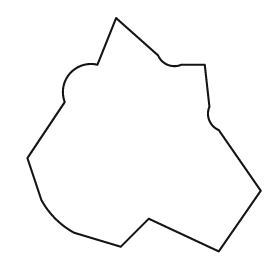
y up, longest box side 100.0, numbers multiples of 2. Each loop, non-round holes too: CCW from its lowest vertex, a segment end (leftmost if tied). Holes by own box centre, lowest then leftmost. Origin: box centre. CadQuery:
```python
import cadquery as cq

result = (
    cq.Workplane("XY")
    .moveTo(32.0, -50.0)
    .lineTo(50.0, -24.0)
    .lineTo(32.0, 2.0)
    .threePointArc((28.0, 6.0), (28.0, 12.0))
    .lineTo(26.0, 30.0)
    .lineTo(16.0, 30.0)
    .threePointArc((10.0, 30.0), (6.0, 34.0))
    .lineTo(-12.0, 50.0)
    .lineTo(-20.0, 30.0)
    .threePointArc((-32.0, 26.0), (-34.0, 14.0))
    .lineTo(-50.0, -10.0)
    .lineTo(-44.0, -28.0)
    .threePointArc((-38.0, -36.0), (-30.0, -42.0))
    .lineTo(-10.0, -48.0)
    .lineTo(2.0, -36.0)
    .close()
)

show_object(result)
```